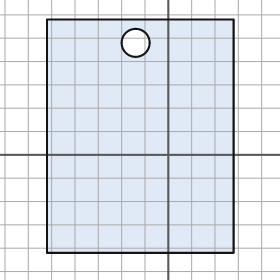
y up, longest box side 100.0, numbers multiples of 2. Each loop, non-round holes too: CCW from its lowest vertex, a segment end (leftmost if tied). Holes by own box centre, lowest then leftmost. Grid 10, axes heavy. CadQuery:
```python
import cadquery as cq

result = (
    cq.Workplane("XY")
    .moveTo(-52.0, -42.0)
    .lineTo(28.0, -42.0)
    .lineTo(28.0, 58.0)
    .lineTo(-52.0, 58.0)
    .close()
    .moveTo(-14.0, 48.0)
    .circle(6.0)
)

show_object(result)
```